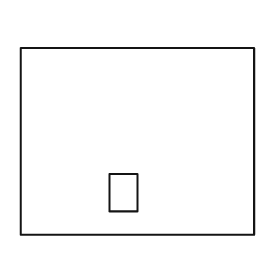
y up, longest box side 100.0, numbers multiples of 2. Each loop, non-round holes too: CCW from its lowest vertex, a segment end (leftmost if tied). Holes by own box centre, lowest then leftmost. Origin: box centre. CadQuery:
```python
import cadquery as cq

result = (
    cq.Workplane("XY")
    .moveTo(-50.0, -40.0)
    .lineTo(50.0, -40.0)
    .lineTo(50.0, 40.0)
    .lineTo(-50.0, 40.0)
    .close()
    .moveTo(-12.0, -30.0)
    .lineTo(0.0, -30.0)
    .lineTo(0.0, -14.0)
    .lineTo(-12.0, -14.0)
    .close()
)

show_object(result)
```